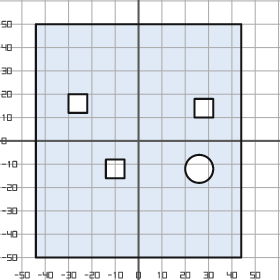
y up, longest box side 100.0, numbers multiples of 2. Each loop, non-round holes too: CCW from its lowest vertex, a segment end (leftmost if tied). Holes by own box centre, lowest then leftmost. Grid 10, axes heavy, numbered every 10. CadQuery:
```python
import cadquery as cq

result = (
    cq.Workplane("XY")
    .moveTo(-44.0, -50.0)
    .lineTo(44.0, -50.0)
    .lineTo(44.0, 50.0)
    .lineTo(-44.0, 50.0)
    .close()
    .moveTo(-14.0, -16.0)
    .lineTo(-6.0, -16.0)
    .lineTo(-6.0, -8.0)
    .lineTo(-14.0, -8.0)
    .close()
    .moveTo(26.0, -12.0)
    .circle(6.0)
    .moveTo(24.0, 10.0)
    .lineTo(32.0, 10.0)
    .lineTo(32.0, 18.0)
    .lineTo(24.0, 18.0)
    .close()
    .moveTo(-30.0, 12.0)
    .lineTo(-22.0, 12.0)
    .lineTo(-22.0, 20.0)
    .lineTo(-30.0, 20.0)
    .close()
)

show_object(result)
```